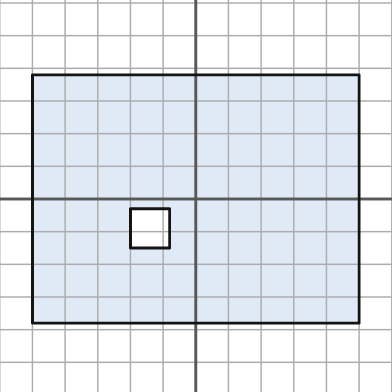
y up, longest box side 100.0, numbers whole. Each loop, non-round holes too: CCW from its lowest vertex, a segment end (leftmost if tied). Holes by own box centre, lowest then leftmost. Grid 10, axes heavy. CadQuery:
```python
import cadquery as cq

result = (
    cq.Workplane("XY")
    .moveTo(-50.0, -38.0)
    .lineTo(50.0, -38.0)
    .lineTo(50.0, 38.0)
    .lineTo(-50.0, 38.0)
    .close()
    .moveTo(-20.0, -15.0)
    .lineTo(-8.0, -15.0)
    .lineTo(-8.0, -3.0)
    .lineTo(-20.0, -3.0)
    .close()
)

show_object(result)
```